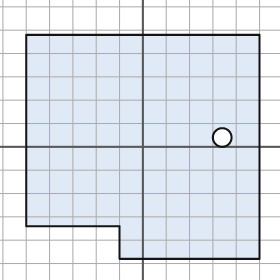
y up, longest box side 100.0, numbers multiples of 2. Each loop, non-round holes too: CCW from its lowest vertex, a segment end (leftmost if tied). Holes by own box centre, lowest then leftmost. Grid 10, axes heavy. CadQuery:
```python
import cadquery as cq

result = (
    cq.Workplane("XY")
    .moveTo(-10.0, -48.0)
    .lineTo(50.0, -48.0)
    .lineTo(50.0, 48.0)
    .lineTo(-50.0, 48.0)
    .lineTo(-50.0, -34.0)
    .lineTo(-10.0, -34.0)
    .close()
    .moveTo(34.0, 4.0)
    .circle(4.0)
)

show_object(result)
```